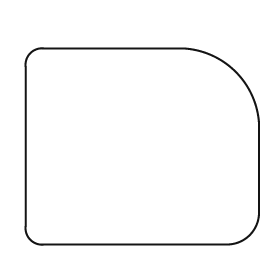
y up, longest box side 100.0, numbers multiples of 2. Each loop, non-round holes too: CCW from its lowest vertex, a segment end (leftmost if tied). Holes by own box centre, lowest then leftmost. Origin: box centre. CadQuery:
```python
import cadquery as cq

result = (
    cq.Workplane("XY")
    .moveTo(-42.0, -42.0)
    .lineTo(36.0, -42.0)
    .threePointArc((46.0, -38.0), (50.0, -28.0))
    .lineTo(50.0, 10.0)
    .threePointArc((40.0, 32.0), (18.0, 42.0))
    .lineTo(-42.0, 42.0)
    .threePointArc((-48.0, 40.0), (-50.0, 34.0))
    .lineTo(-50.0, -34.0)
    .threePointArc((-48.0, -40.0), (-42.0, -42.0))
    .close()
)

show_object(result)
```